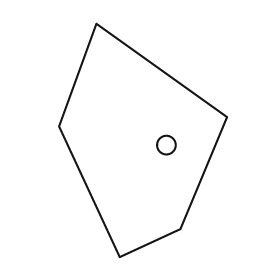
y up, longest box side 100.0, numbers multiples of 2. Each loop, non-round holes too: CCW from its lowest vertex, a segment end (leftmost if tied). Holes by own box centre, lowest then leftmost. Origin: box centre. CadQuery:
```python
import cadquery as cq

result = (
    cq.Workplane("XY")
    .moveTo(-10.0, -50.0)
    .lineTo(16.0, -38.0)
    .lineTo(36.0, 10.0)
    .lineTo(-20.0, 50.0)
    .lineTo(-36.0, 6.0)
    .close()
    .moveTo(10.0, -2.0)
    .circle(4.0)
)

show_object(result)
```